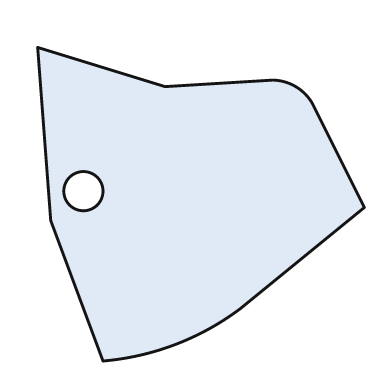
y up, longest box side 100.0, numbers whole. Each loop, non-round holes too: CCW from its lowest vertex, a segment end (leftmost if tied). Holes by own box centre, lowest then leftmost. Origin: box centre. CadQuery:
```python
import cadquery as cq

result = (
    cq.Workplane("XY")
    .moveTo(-30.0, -48.0)
    .threePointArc((-8.0, -43.0), (12.0, -32.0))
    .lineTo(50.0, -1.0)
    .lineTo(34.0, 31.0)
    .threePointArc((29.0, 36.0), (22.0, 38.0))
    .lineTo(-11.0, 36.0)
    .lineTo(-50.0, 48.0)
    .lineTo(-46.0, -5.0)
    .close()
    .moveTo(-36.0, 4.0)
    .circle(6.0)
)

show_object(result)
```